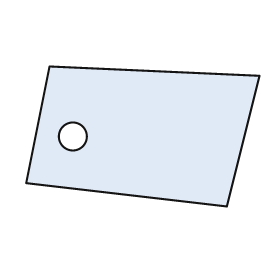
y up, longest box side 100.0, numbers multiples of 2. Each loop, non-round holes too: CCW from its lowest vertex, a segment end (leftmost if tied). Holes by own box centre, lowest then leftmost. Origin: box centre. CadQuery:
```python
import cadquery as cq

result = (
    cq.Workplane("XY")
    .moveTo(36.0, -30.0)
    .lineTo(50.0, 26.0)
    .lineTo(-40.0, 30.0)
    .lineTo(-50.0, -20.0)
    .close()
    .moveTo(-30.0, 0.0)
    .circle(6.0)
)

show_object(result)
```